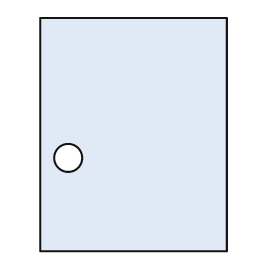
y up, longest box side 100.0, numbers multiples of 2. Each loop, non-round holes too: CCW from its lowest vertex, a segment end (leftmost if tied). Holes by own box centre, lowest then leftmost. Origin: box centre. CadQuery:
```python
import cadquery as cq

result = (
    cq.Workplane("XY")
    .moveTo(-40.0, -50.0)
    .lineTo(40.0, -50.0)
    .lineTo(40.0, 50.0)
    .lineTo(-40.0, 50.0)
    .close()
    .moveTo(-28.0, -10.0)
    .circle(6.0)
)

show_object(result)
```